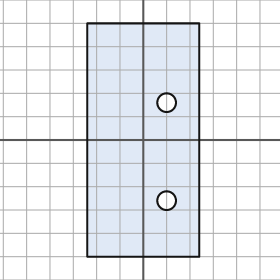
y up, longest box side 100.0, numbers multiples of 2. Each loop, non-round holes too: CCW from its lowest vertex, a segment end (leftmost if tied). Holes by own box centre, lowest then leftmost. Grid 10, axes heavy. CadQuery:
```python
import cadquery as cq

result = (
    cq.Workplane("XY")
    .moveTo(-24.0, -50.0)
    .lineTo(24.0, -50.0)
    .lineTo(24.0, 50.0)
    .lineTo(-24.0, 50.0)
    .close()
    .moveTo(10.0, -26.0)
    .circle(4.0)
    .moveTo(10.0, 16.0)
    .circle(4.0)
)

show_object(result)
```